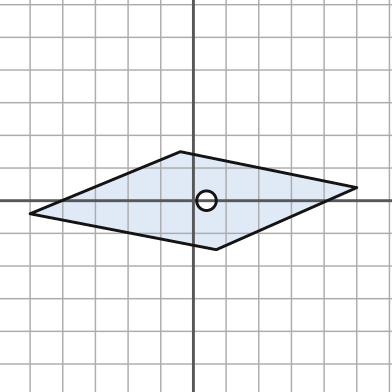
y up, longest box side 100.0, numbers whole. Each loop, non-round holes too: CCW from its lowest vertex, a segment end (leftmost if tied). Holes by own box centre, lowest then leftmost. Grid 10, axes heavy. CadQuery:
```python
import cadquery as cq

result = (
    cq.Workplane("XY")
    .moveTo(7.0, -15.0)
    .lineTo(50.0, 4.0)
    .lineTo(-4.0, 15.0)
    .lineTo(-50.0, -4.0)
    .close()
    .moveTo(4.0, 0.0)
    .circle(3.0)
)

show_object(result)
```